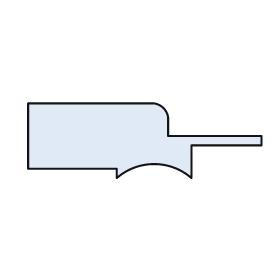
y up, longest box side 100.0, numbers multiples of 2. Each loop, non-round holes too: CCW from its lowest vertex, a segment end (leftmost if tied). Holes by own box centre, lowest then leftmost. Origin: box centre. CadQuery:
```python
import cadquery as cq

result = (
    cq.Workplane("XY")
    .moveTo(-12.0, -16.0)
    .threePointArc((4.0, -10.0), (20.0, -16.0))
    .lineTo(20.0, -2.0)
    .lineTo(50.0, -2.0)
    .lineTo(50.0, 2.0)
    .lineTo(10.0, 2.0)
    .lineTo(10.0, 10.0)
    .threePointArc((8.0, 14.0), (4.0, 16.0))
    .lineTo(-50.0, 16.0)
    .lineTo(-50.0, -12.0)
    .lineTo(-12.0, -12.0)
    .close()
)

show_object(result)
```